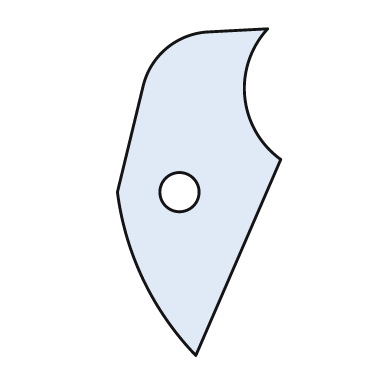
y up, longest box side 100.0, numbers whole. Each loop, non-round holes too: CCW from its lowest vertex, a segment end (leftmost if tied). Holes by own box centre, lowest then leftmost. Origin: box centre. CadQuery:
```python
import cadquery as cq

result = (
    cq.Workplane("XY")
    .moveTo(-1.0, -50.0)
    .lineTo(25.0, 10.0)
    .threePointArc((14.0, 29.0), (21.0, 50.0))
    .lineTo(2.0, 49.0)
    .threePointArc((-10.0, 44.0), (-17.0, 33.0))
    .lineTo(-25.0, 0.0)
    .threePointArc((-17.0, -27.0), (-1.0, -50.0))
    .close()
    .moveTo(-6.0, 0.0)
    .circle(6.0)
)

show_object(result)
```